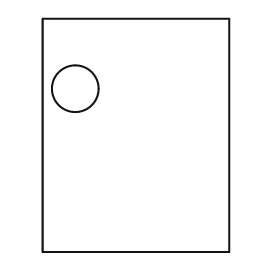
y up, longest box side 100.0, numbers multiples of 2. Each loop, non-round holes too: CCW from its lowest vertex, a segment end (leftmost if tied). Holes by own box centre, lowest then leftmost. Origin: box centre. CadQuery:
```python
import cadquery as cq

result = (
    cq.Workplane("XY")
    .moveTo(-40.0, -50.0)
    .lineTo(40.0, -50.0)
    .lineTo(40.0, 50.0)
    .lineTo(-40.0, 50.0)
    .close()
    .moveTo(-26.0, 20.0)
    .circle(10.0)
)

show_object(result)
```